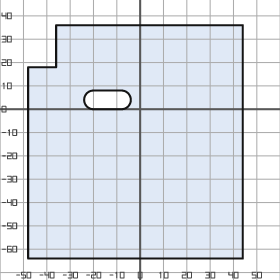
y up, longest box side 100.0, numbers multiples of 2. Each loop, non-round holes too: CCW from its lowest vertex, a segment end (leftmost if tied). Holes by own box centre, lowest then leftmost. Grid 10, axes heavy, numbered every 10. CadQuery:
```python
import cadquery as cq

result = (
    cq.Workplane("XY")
    .moveTo(-48.0, -64.0)
    .lineTo(44.0, -64.0)
    .lineTo(44.0, 36.0)
    .lineTo(-36.0, 36.0)
    .lineTo(-36.0, 18.0)
    .lineTo(-48.0, 18.0)
    .close()
    .moveTo(-20.0, 0.0)
    .lineTo(-8.0, 0.0)
    .threePointArc((-4.0, 4.0), (-8.0, 8.0))
    .lineTo(-20.0, 8.0)
    .threePointArc((-24.0, 4.0), (-20.0, 0.0))
    .close()
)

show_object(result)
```